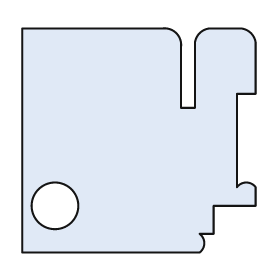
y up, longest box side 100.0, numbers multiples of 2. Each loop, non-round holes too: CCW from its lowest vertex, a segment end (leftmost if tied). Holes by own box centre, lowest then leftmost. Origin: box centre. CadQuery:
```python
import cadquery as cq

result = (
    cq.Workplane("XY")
    .moveTo(-50.0, -48.0)
    .lineTo(26.0, -48.0)
    .threePointArc((28.0, -44.0), (26.0, -40.0))
    .lineTo(32.0, -40.0)
    .lineTo(32.0, -28.0)
    .lineTo(50.0, -28.0)
    .lineTo(50.0, -20.0)
    .threePointArc((46.0, -18.0), (42.0, -20.0))
    .lineTo(42.0, 20.0)
    .lineTo(50.0, 20.0)
    .lineTo(50.0, 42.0)
    .threePointArc((48.0, 46.0), (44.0, 48.0))
    .lineTo(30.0, 48.0)
    .threePointArc((26.0, 46.0), (24.0, 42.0))
    .lineTo(24.0, 14.0)
    .lineTo(18.0, 14.0)
    .lineTo(18.0, 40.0)
    .threePointArc((16.0, 46.0), (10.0, 48.0))
    .lineTo(-50.0, 48.0)
    .close()
    .moveTo(-36.0, -28.0)
    .circle(10.0)
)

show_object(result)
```